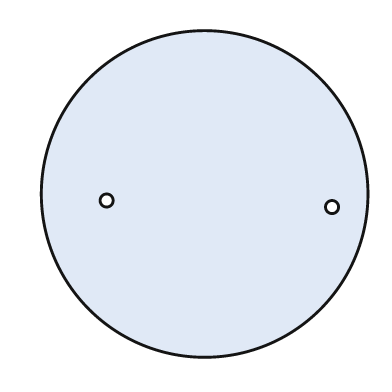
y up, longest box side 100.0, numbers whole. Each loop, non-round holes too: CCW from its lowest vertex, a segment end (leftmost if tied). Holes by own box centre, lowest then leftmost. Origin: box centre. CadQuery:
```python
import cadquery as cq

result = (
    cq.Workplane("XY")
    .moveTo(0.0, 0.0)
    .circle(50.0)
    .moveTo(39.0, -4.0)
    .circle(2.0)
    .moveTo(-30.0, -2.0)
    .circle(2.0)
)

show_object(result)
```